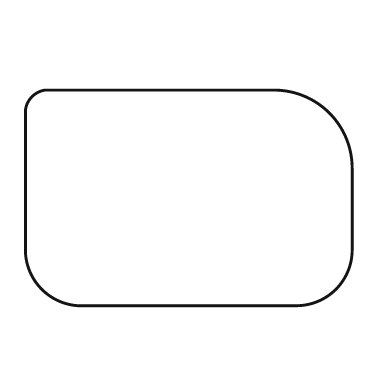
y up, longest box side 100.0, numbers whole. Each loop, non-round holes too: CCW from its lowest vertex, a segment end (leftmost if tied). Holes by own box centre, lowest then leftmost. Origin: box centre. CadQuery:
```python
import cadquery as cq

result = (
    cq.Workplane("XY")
    .moveTo(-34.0, -33.0)
    .lineTo(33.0, -33.0)
    .threePointArc((45.0, -28.0), (50.0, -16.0))
    .lineTo(50.0, 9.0)
    .threePointArc((43.0, 26.0), (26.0, 33.0))
    .lineTo(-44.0, 33.0)
    .threePointArc((-48.0, 31.0), (-50.0, 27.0))
    .lineTo(-50.0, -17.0)
    .threePointArc((-45.0, -28.0), (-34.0, -33.0))
    .close()
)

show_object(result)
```